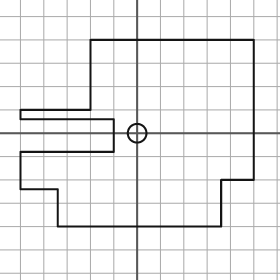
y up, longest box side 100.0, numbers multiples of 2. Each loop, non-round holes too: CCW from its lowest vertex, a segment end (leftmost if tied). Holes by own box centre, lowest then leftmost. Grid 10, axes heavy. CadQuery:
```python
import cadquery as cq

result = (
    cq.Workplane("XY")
    .moveTo(-34.0, -40.0)
    .lineTo(36.0, -40.0)
    .lineTo(36.0, -20.0)
    .lineTo(50.0, -20.0)
    .lineTo(50.0, 40.0)
    .lineTo(-20.0, 40.0)
    .lineTo(-20.0, 10.0)
    .lineTo(-50.0, 10.0)
    .lineTo(-50.0, 6.0)
    .lineTo(-10.0, 6.0)
    .lineTo(-10.0, -8.0)
    .lineTo(-50.0, -8.0)
    .lineTo(-50.0, -24.0)
    .lineTo(-34.0, -24.0)
    .close()
    .moveTo(0.0, 0.0)
    .circle(4.0)
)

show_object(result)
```